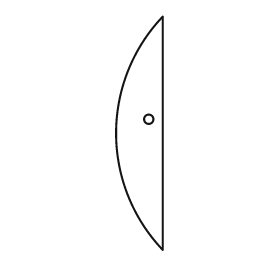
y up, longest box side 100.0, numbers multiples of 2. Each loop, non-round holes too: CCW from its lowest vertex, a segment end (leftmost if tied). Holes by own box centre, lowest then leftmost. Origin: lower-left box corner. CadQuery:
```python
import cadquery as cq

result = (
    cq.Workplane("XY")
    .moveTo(20.0, 0.0)
    .lineTo(20.0, 100.0)
    .threePointArc((0.0, 50.0), (20.0, 0.0))
    .close()
    .moveTo(14.0, 56.0)
    .circle(2.0)
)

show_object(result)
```